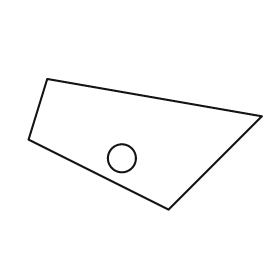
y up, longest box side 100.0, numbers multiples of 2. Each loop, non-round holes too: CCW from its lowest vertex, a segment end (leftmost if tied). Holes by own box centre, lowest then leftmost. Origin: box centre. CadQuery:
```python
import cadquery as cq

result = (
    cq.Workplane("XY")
    .moveTo(10.0, -28.0)
    .lineTo(50.0, 12.0)
    .lineTo(-42.0, 28.0)
    .lineTo(-50.0, 2.0)
    .close()
    .moveTo(-10.0, -6.0)
    .circle(6.0)
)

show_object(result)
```